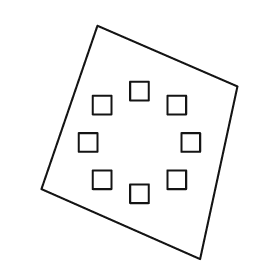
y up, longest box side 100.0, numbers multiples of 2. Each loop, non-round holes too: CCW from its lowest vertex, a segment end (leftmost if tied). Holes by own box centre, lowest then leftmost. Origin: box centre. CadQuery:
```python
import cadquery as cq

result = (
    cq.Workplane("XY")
    .moveTo(26.0, -50.0)
    .lineTo(42.0, 24.0)
    .lineTo(-18.0, 50.0)
    .lineTo(-42.0, -20.0)
    .close()
    .moveTo(-4.0, -26.0)
    .lineTo(4.0, -26.0)
    .lineTo(4.0, -18.0)
    .lineTo(-4.0, -18.0)
    .close()
    .moveTo(-20.0, -20.0)
    .lineTo(-12.0, -20.0)
    .lineTo(-12.0, -12.0)
    .lineTo(-20.0, -12.0)
    .close()
    .moveTo(12.0, -20.0)
    .lineTo(20.0, -20.0)
    .lineTo(20.0, -12.0)
    .lineTo(12.0, -12.0)
    .close()
    .moveTo(-26.0, -4.0)
    .lineTo(-18.0, -4.0)
    .lineTo(-18.0, 4.0)
    .lineTo(-26.0, 4.0)
    .close()
    .moveTo(18.0, -4.0)
    .lineTo(26.0, -4.0)
    .lineTo(26.0, 4.0)
    .lineTo(18.0, 4.0)
    .close()
    .moveTo(-20.0, 12.0)
    .lineTo(-12.0, 12.0)
    .lineTo(-12.0, 20.0)
    .lineTo(-20.0, 20.0)
    .close()
    .moveTo(12.0, 12.0)
    .lineTo(20.0, 12.0)
    .lineTo(20.0, 20.0)
    .lineTo(12.0, 20.0)
    .close()
    .moveTo(-4.0, 18.0)
    .lineTo(4.0, 18.0)
    .lineTo(4.0, 26.0)
    .lineTo(-4.0, 26.0)
    .close()
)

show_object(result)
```